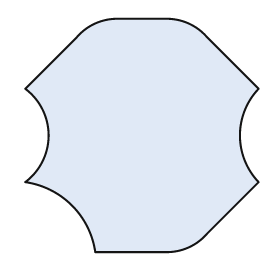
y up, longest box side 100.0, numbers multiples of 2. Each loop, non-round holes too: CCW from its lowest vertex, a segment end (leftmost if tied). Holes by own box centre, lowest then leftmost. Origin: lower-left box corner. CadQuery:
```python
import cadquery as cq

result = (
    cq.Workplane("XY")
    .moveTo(30.0, 0.0)
    .lineTo(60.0, 0.0)
    .threePointArc((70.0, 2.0), (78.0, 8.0))
    .lineTo(100.0, 30.0)
    .threePointArc((92.0, 50.0), (100.0, 70.0))
    .lineTo(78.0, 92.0)
    .threePointArc((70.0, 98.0), (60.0, 100.0))
    .lineTo(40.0, 100.0)
    .threePointArc((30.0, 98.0), (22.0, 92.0))
    .lineTo(0.0, 70.0)
    .threePointArc((10.0, 50.0), (0.0, 30.0))
    .threePointArc((20.0, 20.0), (30.0, 0.0))
    .close()
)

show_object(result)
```